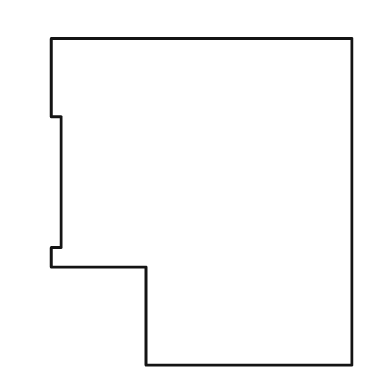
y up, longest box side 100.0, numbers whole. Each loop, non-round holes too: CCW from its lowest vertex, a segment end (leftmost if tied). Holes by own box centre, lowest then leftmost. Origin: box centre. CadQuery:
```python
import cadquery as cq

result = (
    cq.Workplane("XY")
    .moveTo(-17.0, -50.0)
    .lineTo(46.0, -50.0)
    .lineTo(46.0, 50.0)
    .lineTo(-46.0, 50.0)
    .lineTo(-46.0, 26.0)
    .lineTo(-43.0, 26.0)
    .lineTo(-43.0, -14.0)
    .lineTo(-46.0, -14.0)
    .lineTo(-46.0, -20.0)
    .lineTo(-17.0, -20.0)
    .close()
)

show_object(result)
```